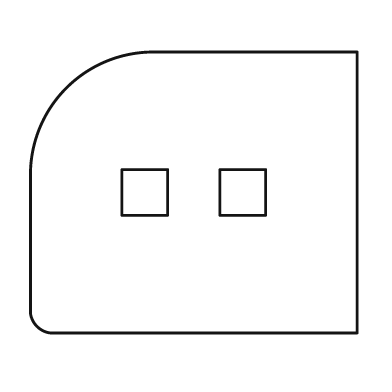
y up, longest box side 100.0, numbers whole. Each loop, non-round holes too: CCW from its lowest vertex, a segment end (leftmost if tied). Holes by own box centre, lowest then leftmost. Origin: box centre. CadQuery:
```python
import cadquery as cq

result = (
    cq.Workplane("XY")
    .moveTo(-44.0, -43.0)
    .lineTo(50.0, -43.0)
    .lineTo(50.0, 43.0)
    .lineTo(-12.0, 43.0)
    .threePointArc((-39.0, 32.0), (-50.0, 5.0))
    .lineTo(-50.0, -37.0)
    .threePointArc((-48.0, -41.0), (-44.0, -43.0))
    .close()
    .moveTo(-22.0, -7.0)
    .lineTo(-8.0, -7.0)
    .lineTo(-8.0, 7.0)
    .lineTo(-22.0, 7.0)
    .close()
    .moveTo(8.0, -7.0)
    .lineTo(22.0, -7.0)
    .lineTo(22.0, 7.0)
    .lineTo(8.0, 7.0)
    .close()
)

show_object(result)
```